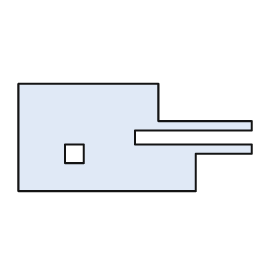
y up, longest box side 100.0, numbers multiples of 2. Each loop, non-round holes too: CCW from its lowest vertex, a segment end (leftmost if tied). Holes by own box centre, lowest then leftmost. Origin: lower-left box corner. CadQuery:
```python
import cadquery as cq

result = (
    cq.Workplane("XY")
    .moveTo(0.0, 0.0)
    .lineTo(76.0, 0.0)
    .lineTo(76.0, 16.0)
    .lineTo(100.0, 16.0)
    .lineTo(100.0, 20.0)
    .lineTo(50.0, 20.0)
    .lineTo(50.0, 26.0)
    .lineTo(100.0, 26.0)
    .lineTo(100.0, 30.0)
    .lineTo(60.0, 30.0)
    .lineTo(60.0, 46.0)
    .lineTo(0.0, 46.0)
    .close()
    .moveTo(20.0, 12.0)
    .lineTo(28.0, 12.0)
    .lineTo(28.0, 20.0)
    .lineTo(20.0, 20.0)
    .close()
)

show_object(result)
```